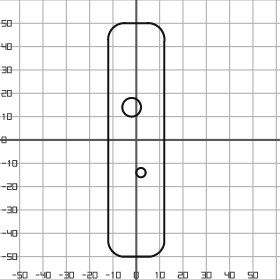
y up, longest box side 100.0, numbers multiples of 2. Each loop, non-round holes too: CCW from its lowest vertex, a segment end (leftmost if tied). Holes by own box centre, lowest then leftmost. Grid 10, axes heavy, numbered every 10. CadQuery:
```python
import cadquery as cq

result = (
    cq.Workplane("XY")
    .moveTo(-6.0, -50.0)
    .lineTo(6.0, -50.0)
    .threePointArc((10.0, -48.0), (12.0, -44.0))
    .lineTo(12.0, 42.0)
    .threePointArc((10.0, 48.0), (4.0, 50.0))
    .lineTo(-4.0, 50.0)
    .threePointArc((-10.0, 48.0), (-12.0, 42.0))
    .lineTo(-12.0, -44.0)
    .threePointArc((-10.0, -48.0), (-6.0, -50.0))
    .close()
    .moveTo(2.0, -14.0)
    .circle(2.0)
    .moveTo(-2.0, 14.0)
    .circle(4.0)
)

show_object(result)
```